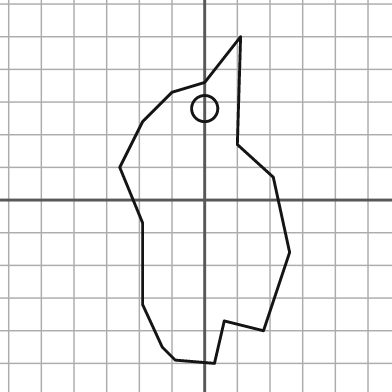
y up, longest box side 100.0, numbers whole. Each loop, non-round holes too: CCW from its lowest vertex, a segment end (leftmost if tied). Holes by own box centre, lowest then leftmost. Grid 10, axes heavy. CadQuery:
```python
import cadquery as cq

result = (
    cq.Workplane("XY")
    .moveTo(3.0, -50.0)
    .lineTo(6.0, -37.0)
    .lineTo(18.0, -40.0)
    .lineTo(26.0, -16.0)
    .lineTo(21.0, 7.0)
    .lineTo(10.0, 17.0)
    .lineTo(11.0, 50.0)
    .lineTo(0.0, 36.0)
    .lineTo(-10.0, 33.0)
    .lineTo(-19.0, 24.0)
    .lineTo(-26.0, 10.0)
    .lineTo(-19.0, -7.0)
    .lineTo(-19.0, -32.0)
    .lineTo(-13.0, -45.0)
    .lineTo(-9.0, -49.0)
    .close()
    .moveTo(0.0, 28.0)
    .circle(4.0)
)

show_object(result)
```